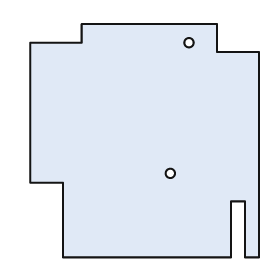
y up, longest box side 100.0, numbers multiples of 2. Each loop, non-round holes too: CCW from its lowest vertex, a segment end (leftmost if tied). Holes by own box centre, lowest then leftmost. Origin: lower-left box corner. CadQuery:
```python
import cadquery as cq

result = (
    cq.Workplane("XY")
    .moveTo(14.0, 0.0)
    .lineTo(86.0, 0.0)
    .lineTo(86.0, 24.0)
    .lineTo(92.0, 24.0)
    .lineTo(92.0, 0.0)
    .lineTo(98.0, 0.0)
    .lineTo(98.0, 88.0)
    .lineTo(80.0, 88.0)
    .lineTo(80.0, 100.0)
    .lineTo(22.0, 100.0)
    .lineTo(22.0, 92.0)
    .lineTo(0.0, 92.0)
    .lineTo(0.0, 32.0)
    .lineTo(14.0, 32.0)
    .close()
    .moveTo(60.0, 36.0)
    .circle(2.0)
    .moveTo(68.0, 92.0)
    .circle(2.0)
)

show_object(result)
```